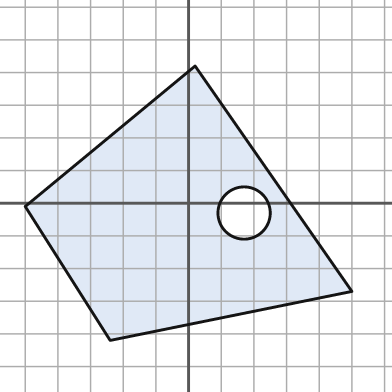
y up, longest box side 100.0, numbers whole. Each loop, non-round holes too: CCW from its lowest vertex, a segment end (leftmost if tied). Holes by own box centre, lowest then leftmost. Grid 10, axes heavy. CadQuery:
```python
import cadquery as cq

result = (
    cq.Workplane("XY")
    .moveTo(-24.0, -42.0)
    .lineTo(50.0, -27.0)
    .lineTo(2.0, 42.0)
    .lineTo(-50.0, -1.0)
    .close()
    .moveTo(17.0, -3.0)
    .circle(8.0)
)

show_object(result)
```